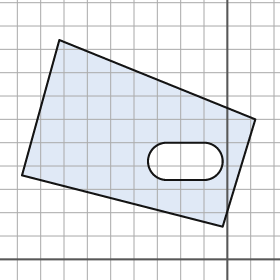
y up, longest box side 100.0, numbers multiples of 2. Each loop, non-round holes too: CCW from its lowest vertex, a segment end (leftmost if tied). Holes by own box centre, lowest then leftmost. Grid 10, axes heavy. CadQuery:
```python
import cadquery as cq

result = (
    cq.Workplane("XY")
    .moveTo(-2.0, 14.0)
    .lineTo(12.0, 60.0)
    .lineTo(-72.0, 94.0)
    .lineTo(-88.0, 36.0)
    .close()
    .moveTo(-26.0, 34.0)
    .lineTo(-10.0, 34.0)
    .threePointArc((-2.0, 42.0), (-10.0, 50.0))
    .lineTo(-26.0, 50.0)
    .threePointArc((-34.0, 42.0), (-26.0, 34.0))
    .close()
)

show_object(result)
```